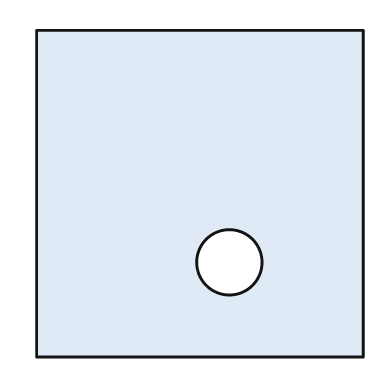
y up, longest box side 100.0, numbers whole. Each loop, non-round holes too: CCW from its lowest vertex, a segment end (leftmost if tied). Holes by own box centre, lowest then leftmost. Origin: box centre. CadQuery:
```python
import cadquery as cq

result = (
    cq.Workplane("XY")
    .moveTo(-50.0, -50.0)
    .lineTo(50.0, -50.0)
    .lineTo(50.0, 50.0)
    .lineTo(-50.0, 50.0)
    .close()
    .moveTo(9.0, -21.0)
    .circle(10.0)
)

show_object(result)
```